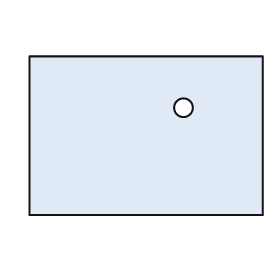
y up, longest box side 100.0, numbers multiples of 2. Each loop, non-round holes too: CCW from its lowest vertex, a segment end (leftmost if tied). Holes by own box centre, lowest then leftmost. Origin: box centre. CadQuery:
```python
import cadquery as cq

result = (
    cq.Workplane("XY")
    .moveTo(-50.0, -34.0)
    .lineTo(50.0, -34.0)
    .lineTo(50.0, 34.0)
    .lineTo(-50.0, 34.0)
    .close()
    .moveTo(16.0, 12.0)
    .circle(4.0)
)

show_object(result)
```